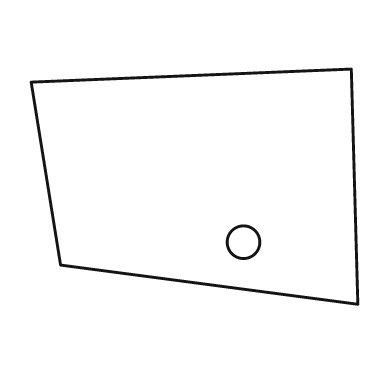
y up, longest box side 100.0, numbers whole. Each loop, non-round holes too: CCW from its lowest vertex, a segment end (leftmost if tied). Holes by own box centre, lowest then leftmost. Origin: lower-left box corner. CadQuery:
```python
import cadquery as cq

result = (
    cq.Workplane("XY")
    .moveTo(100.0, 0.0)
    .lineTo(98.0, 72.0)
    .lineTo(0.0, 68.0)
    .lineTo(9.0, 12.0)
    .close()
    .moveTo(65.0, 19.0)
    .circle(5.0)
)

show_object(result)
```